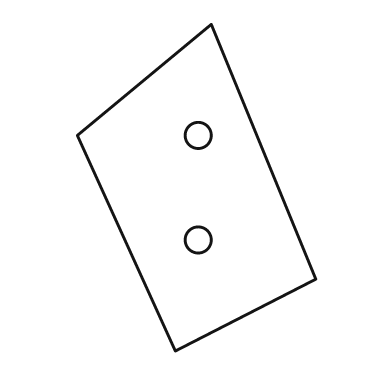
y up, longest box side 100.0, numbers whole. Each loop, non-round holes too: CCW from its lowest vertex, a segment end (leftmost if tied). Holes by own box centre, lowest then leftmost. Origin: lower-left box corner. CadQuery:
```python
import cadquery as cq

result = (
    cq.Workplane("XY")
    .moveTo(30.0, 0.0)
    .lineTo(73.0, 22.0)
    .lineTo(41.0, 100.0)
    .lineTo(0.0, 66.0)
    .close()
    .moveTo(37.0, 34.0)
    .circle(4.0)
    .moveTo(37.0, 66.0)
    .circle(4.0)
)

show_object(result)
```